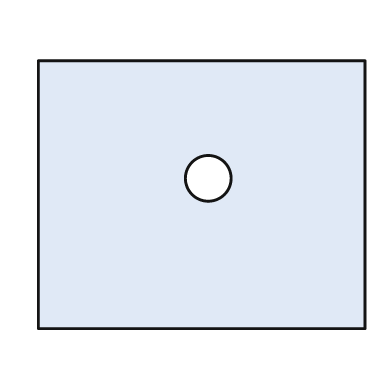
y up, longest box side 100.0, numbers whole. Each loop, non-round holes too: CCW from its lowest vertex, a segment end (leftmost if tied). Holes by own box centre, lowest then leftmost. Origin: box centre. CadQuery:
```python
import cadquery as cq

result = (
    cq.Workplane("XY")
    .moveTo(-50.0, -41.0)
    .lineTo(50.0, -41.0)
    .lineTo(50.0, 41.0)
    .lineTo(-50.0, 41.0)
    .close()
    .moveTo(2.0, 5.0)
    .circle(7.0)
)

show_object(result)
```